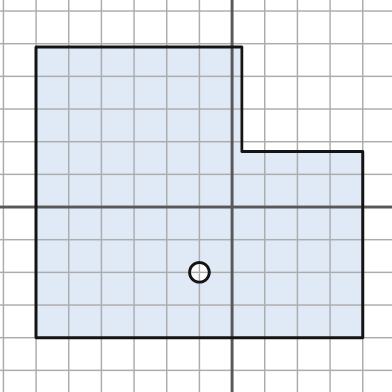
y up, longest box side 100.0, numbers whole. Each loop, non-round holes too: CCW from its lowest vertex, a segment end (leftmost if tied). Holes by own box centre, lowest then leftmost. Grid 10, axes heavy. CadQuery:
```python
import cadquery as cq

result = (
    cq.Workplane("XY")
    .moveTo(-60.0, -40.0)
    .lineTo(40.0, -40.0)
    .lineTo(40.0, 17.0)
    .lineTo(3.0, 17.0)
    .lineTo(3.0, 49.0)
    .lineTo(-60.0, 49.0)
    .close()
    .moveTo(-10.0, -20.0)
    .circle(3.0)
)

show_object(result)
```